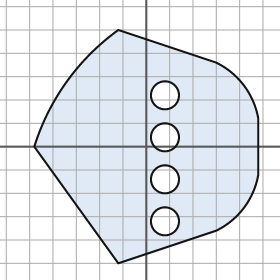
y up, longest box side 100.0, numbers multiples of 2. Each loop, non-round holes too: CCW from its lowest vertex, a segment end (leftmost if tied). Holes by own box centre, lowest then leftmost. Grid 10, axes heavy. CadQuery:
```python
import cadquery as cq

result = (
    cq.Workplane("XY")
    .moveTo(-12.0, -50.0)
    .lineTo(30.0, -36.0)
    .threePointArc((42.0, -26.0), (48.0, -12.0))
    .lineTo(48.0, 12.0)
    .threePointArc((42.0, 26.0), (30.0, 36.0))
    .lineTo(-12.0, 50.0)
    .threePointArc((-34.0, 28.0), (-48.0, 0.0))
    .close()
    .moveTo(8.0, -32.0)
    .circle(6.0)
    .moveTo(8.0, -14.0)
    .circle(6.0)
    .moveTo(8.0, 4.0)
    .circle(6.0)
    .moveTo(8.0, 22.0)
    .circle(6.0)
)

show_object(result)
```